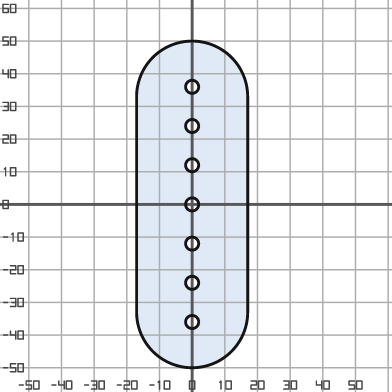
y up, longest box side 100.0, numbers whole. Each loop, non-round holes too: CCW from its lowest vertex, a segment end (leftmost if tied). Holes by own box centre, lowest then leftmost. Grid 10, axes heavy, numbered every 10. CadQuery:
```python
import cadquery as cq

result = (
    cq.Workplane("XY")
    .moveTo(-17.0, -33.0)
    .threePointArc((0.0, -50.0), (17.0, -33.0))
    .lineTo(17.0, 33.0)
    .threePointArc((0.0, 50.0), (-17.0, 33.0))
    .close()
    .moveTo(0.0, -36.0)
    .circle(2.0)
    .moveTo(0.0, -24.0)
    .circle(2.0)
    .moveTo(0.0, -12.0)
    .circle(2.0)
    .moveTo(0.0, 0.0)
    .circle(2.0)
    .moveTo(0.0, 12.0)
    .circle(2.0)
    .moveTo(0.0, 24.0)
    .circle(2.0)
    .moveTo(0.0, 36.0)
    .circle(2.0)
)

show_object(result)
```